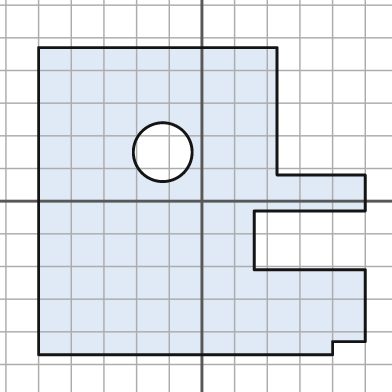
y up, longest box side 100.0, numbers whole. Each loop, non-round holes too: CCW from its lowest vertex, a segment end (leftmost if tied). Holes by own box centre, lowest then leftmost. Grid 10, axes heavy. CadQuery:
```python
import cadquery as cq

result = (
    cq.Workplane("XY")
    .moveTo(-50.0, -47.0)
    .lineTo(40.0, -47.0)
    .lineTo(40.0, -43.0)
    .lineTo(50.0, -43.0)
    .lineTo(50.0, -21.0)
    .lineTo(16.0, -21.0)
    .lineTo(16.0, -3.0)
    .lineTo(50.0, -3.0)
    .lineTo(50.0, 8.0)
    .lineTo(23.0, 8.0)
    .lineTo(23.0, 47.0)
    .lineTo(-50.0, 47.0)
    .close()
    .moveTo(-12.0, 15.0)
    .circle(9.0)
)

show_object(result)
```